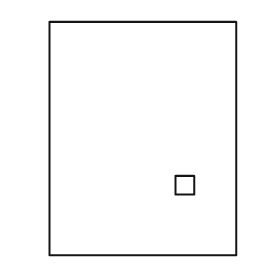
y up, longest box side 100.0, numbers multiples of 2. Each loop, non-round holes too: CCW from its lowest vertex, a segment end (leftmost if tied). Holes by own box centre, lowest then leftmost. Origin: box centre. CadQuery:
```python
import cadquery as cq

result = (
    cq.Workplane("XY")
    .moveTo(-40.0, -50.0)
    .lineTo(40.0, -50.0)
    .lineTo(40.0, 50.0)
    .lineTo(-40.0, 50.0)
    .close()
    .moveTo(14.0, -24.0)
    .lineTo(22.0, -24.0)
    .lineTo(22.0, -16.0)
    .lineTo(14.0, -16.0)
    .close()
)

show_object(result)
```